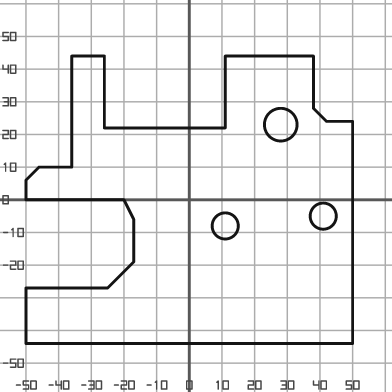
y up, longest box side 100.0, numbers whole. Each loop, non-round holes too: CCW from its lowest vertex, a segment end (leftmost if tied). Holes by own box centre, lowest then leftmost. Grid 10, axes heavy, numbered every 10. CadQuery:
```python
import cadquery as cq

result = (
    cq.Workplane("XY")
    .moveTo(-50.0, -44.0)
    .lineTo(50.0, -44.0)
    .lineTo(50.0, 24.0)
    .lineTo(42.0, 24.0)
    .lineTo(38.0, 28.0)
    .lineTo(38.0, 44.0)
    .lineTo(11.0, 44.0)
    .lineTo(11.0, 22.0)
    .lineTo(-26.0, 22.0)
    .lineTo(-26.0, 44.0)
    .lineTo(-36.0, 44.0)
    .lineTo(-36.0, 10.0)
    .lineTo(-46.0, 10.0)
    .lineTo(-50.0, 6.0)
    .lineTo(-50.0, 0.0)
    .lineTo(-20.0, 0.0)
    .lineTo(-17.0, -6.0)
    .lineTo(-17.0, -19.0)
    .lineTo(-25.0, -27.0)
    .lineTo(-50.0, -27.0)
    .close()
    .moveTo(11.0, -8.0)
    .circle(4.0)
    .moveTo(41.0, -5.0)
    .circle(4.0)
    .moveTo(28.0, 23.0)
    .circle(5.0)
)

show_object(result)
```